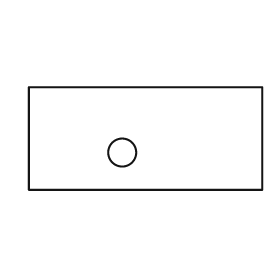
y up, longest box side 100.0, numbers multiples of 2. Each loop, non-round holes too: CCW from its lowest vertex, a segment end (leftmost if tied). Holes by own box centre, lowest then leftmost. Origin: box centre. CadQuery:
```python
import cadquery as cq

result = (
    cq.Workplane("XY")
    .moveTo(-50.0, -22.0)
    .lineTo(50.0, -22.0)
    .lineTo(50.0, 22.0)
    .lineTo(-50.0, 22.0)
    .close()
    .moveTo(-10.0, -6.0)
    .circle(6.0)
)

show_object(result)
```